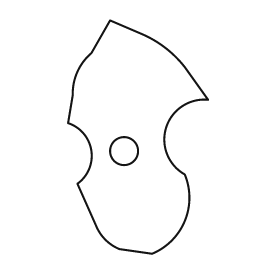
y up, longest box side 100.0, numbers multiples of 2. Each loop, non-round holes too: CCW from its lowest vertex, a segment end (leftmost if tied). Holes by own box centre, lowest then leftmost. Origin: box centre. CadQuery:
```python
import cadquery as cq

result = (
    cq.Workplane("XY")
    .moveTo(6.0, -50.0)
    .threePointArc((20.0, -36.0), (20.0, -16.0))
    .threePointArc((12.0, 4.0), (30.0, 16.0))
    .lineTo(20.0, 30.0)
    .threePointArc((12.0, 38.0), (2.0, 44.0))
    .lineTo(-12.0, 50.0)
    .lineTo(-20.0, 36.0)
    .threePointArc((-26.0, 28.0), (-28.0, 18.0))
    .lineTo(-30.0, 6.0)
    .threePointArc((-20.0, -6.0), (-26.0, -20.0))
    .lineTo(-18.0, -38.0)
    .threePointArc((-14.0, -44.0), (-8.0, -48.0))
    .close()
    .moveTo(-6.0, -6.0)
    .circle(6.0)
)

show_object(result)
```